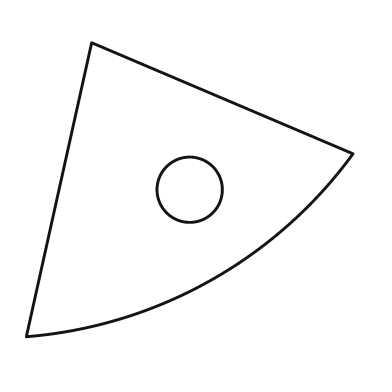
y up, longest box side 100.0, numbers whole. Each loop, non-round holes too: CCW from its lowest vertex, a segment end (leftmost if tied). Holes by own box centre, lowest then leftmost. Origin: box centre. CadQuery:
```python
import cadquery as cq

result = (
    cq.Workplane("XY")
    .moveTo(-50.0, -45.0)
    .threePointArc((6.0, -28.0), (50.0, 11.0))
    .lineTo(-30.0, 45.0)
    .close()
    .moveTo(0.0, 0.0)
    .circle(10.0)
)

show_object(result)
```